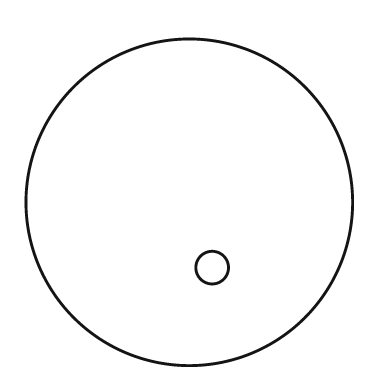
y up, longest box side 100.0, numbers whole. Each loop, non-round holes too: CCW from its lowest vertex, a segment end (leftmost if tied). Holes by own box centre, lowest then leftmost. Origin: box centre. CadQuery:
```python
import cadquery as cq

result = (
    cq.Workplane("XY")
    .moveTo(0.0, 0.0)
    .circle(50.0)
    .moveTo(7.0, -20.0)
    .circle(5.0)
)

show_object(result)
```